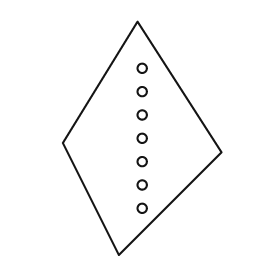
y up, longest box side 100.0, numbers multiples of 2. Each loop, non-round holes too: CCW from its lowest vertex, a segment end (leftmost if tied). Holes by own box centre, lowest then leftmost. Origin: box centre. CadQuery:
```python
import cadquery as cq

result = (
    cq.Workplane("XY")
    .moveTo(-10.0, -50.0)
    .lineTo(34.0, -6.0)
    .lineTo(-2.0, 50.0)
    .lineTo(-34.0, -2.0)
    .close()
    .moveTo(0.0, -30.0)
    .circle(2.0)
    .moveTo(0.0, -20.0)
    .circle(2.0)
    .moveTo(0.0, -10.0)
    .circle(2.0)
    .moveTo(0.0, 0.0)
    .circle(2.0)
    .moveTo(0.0, 10.0)
    .circle(2.0)
    .moveTo(0.0, 20.0)
    .circle(2.0)
    .moveTo(0.0, 30.0)
    .circle(2.0)
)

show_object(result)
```